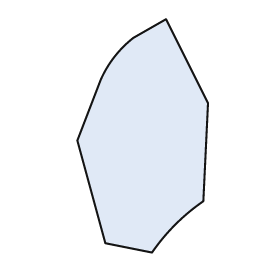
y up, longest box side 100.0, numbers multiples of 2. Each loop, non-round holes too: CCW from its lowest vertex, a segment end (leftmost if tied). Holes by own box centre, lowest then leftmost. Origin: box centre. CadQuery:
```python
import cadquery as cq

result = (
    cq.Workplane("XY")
    .moveTo(4.0, -50.0)
    .threePointArc((14.0, -38.0), (26.0, -28.0))
    .lineTo(28.0, 14.0)
    .lineTo(10.0, 50.0)
    .lineTo(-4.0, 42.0)
    .threePointArc((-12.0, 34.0), (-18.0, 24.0))
    .lineTo(-28.0, -2.0)
    .lineTo(-16.0, -46.0)
    .close()
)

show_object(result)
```